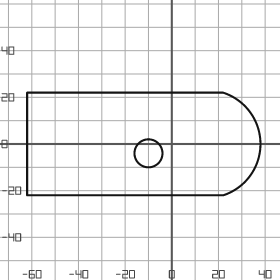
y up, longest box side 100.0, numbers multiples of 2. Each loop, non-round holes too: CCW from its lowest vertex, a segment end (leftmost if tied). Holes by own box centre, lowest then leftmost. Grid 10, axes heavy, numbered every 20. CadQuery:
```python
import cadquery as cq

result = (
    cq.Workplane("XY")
    .moveTo(-62.0, -22.0)
    .lineTo(22.0, -22.0)
    .threePointArc((38.0, 0.0), (22.0, 22.0))
    .lineTo(-62.0, 22.0)
    .close()
    .moveTo(-10.0, -4.0)
    .circle(6.0)
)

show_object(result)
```